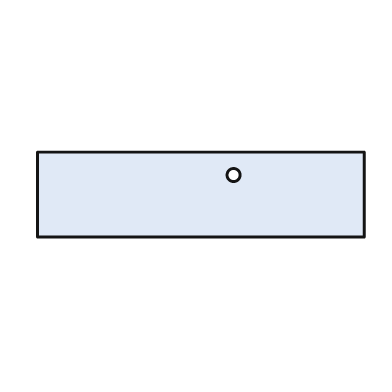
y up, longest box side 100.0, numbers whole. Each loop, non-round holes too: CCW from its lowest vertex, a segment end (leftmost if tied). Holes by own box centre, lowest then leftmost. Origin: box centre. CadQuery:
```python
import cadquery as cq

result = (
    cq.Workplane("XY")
    .moveTo(-50.0, -13.0)
    .lineTo(50.0, -13.0)
    .lineTo(50.0, 13.0)
    .lineTo(-50.0, 13.0)
    .close()
    .moveTo(10.0, 6.0)
    .circle(2.0)
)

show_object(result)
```